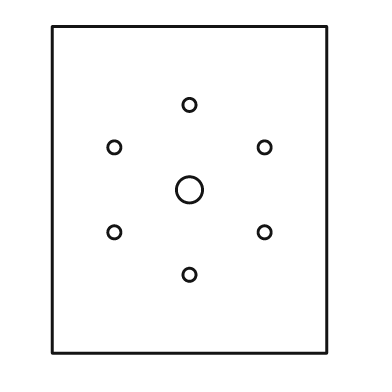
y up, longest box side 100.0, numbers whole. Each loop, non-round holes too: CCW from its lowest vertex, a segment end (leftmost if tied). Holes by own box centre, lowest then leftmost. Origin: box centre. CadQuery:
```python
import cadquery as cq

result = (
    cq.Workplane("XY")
    .moveTo(-42.0, -50.0)
    .lineTo(42.0, -50.0)
    .lineTo(42.0, 50.0)
    .lineTo(-42.0, 50.0)
    .close()
    .moveTo(0.0, -26.0)
    .circle(2.0)
    .moveTo(-23.0, -13.0)
    .circle(2.0)
    .moveTo(23.0, -13.0)
    .circle(2.0)
    .moveTo(0.0, 0.0)
    .circle(4.0)
    .moveTo(-23.0, 13.0)
    .circle(2.0)
    .moveTo(23.0, 13.0)
    .circle(2.0)
    .moveTo(0.0, 26.0)
    .circle(2.0)
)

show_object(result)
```